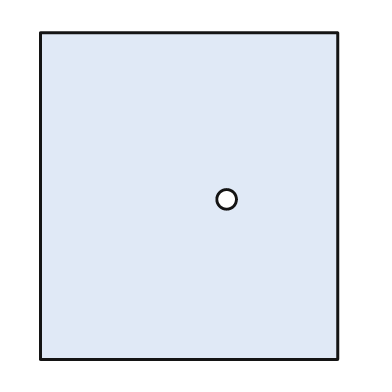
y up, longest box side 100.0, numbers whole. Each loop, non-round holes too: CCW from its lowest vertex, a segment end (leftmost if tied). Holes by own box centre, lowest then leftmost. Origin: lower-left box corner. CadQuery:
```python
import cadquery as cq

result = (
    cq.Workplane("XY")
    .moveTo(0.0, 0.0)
    .lineTo(91.0, 0.0)
    .lineTo(91.0, 100.0)
    .lineTo(0.0, 100.0)
    .close()
    .moveTo(57.0, 49.0)
    .circle(3.0)
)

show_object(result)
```